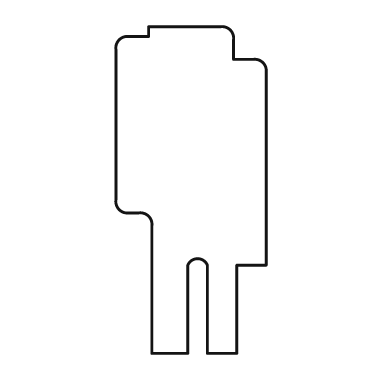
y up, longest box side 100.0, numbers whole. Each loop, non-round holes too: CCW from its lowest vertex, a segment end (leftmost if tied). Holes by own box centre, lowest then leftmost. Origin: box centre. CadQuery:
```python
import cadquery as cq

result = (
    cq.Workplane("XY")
    .moveTo(-12.0, -50.0)
    .lineTo(-1.0, -50.0)
    .lineTo(-1.0, -23.0)
    .threePointArc((2.0, -21.0), (5.0, -23.0))
    .lineTo(5.0, -50.0)
    .lineTo(14.0, -50.0)
    .lineTo(14.0, -23.0)
    .lineTo(23.0, -23.0)
    .lineTo(23.0, 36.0)
    .threePointArc((22.0, 39.0), (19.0, 40.0))
    .lineTo(13.0, 40.0)
    .lineTo(13.0, 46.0)
    .threePointArc((12.0, 49.0), (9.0, 50.0))
    .lineTo(-13.0, 50.0)
    .lineTo(-13.0, 47.0)
    .lineTo(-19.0, 47.0)
    .threePointArc((-22.0, 46.0), (-23.0, 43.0))
    .lineTo(-23.0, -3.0)
    .threePointArc((-22.0, -6.0), (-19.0, -7.0))
    .lineTo(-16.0, -7.0)
    .threePointArc((-13.0, -8.0), (-12.0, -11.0))
    .close()
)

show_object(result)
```